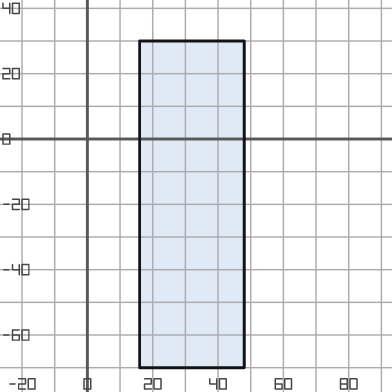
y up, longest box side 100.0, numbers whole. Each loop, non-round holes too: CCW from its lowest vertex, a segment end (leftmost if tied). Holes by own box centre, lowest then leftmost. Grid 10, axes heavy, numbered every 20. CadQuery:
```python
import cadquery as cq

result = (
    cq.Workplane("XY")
    .moveTo(16.0, -70.0)
    .lineTo(48.0, -70.0)
    .lineTo(48.0, 30.0)
    .lineTo(16.0, 30.0)
    .close()
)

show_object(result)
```